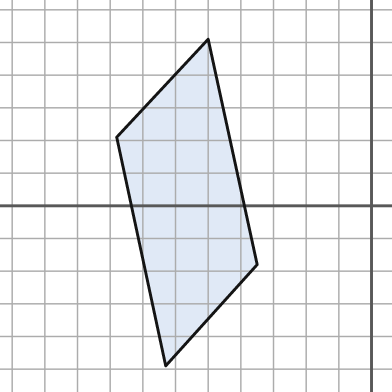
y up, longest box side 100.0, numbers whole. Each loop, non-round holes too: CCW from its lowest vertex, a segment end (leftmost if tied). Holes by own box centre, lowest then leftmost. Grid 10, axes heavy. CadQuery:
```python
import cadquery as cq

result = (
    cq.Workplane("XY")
    .moveTo(-63.0, -49.0)
    .lineTo(-35.0, -18.0)
    .lineTo(-50.0, 51.0)
    .lineTo(-78.0, 21.0)
    .close()
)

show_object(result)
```